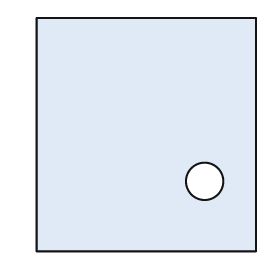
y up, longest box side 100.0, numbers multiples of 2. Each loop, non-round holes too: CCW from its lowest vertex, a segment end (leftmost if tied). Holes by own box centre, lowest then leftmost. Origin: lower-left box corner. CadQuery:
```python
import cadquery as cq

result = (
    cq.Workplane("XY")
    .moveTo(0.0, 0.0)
    .lineTo(94.0, 0.0)
    .lineTo(94.0, 100.0)
    .lineTo(0.0, 100.0)
    .close()
    .moveTo(72.0, 30.0)
    .circle(8.0)
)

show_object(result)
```